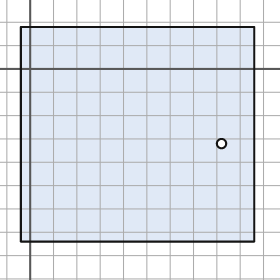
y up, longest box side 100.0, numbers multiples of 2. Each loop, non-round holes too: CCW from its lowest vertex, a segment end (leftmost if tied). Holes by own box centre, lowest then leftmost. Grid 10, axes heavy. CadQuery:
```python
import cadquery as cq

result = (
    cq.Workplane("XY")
    .moveTo(-4.0, -74.0)
    .lineTo(96.0, -74.0)
    .lineTo(96.0, 18.0)
    .lineTo(-4.0, 18.0)
    .close()
    .moveTo(82.0, -32.0)
    .circle(2.0)
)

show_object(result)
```